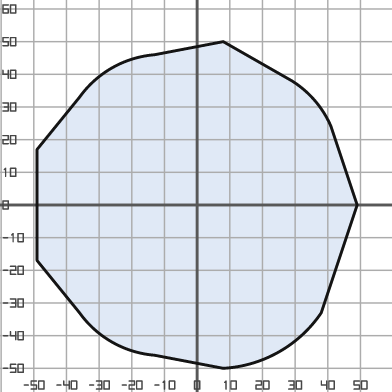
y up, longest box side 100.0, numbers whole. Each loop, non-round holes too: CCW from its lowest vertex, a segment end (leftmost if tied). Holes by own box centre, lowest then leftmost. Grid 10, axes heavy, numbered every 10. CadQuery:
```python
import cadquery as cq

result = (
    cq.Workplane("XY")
    .moveTo(8.0, -50.0)
    .threePointArc((25.0, -45.0), (38.0, -33.0))
    .lineTo(49.0, 0.0)
    .lineTo(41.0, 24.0)
    .threePointArc((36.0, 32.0), (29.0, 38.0))
    .lineTo(8.0, 50.0)
    .lineTo(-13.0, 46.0)
    .threePointArc((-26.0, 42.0), (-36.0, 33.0))
    .lineTo(-49.0, 17.0)
    .lineTo(-49.0, -17.0)
    .lineTo(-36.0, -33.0)
    .threePointArc((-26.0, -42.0), (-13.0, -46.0))
    .close()
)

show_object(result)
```